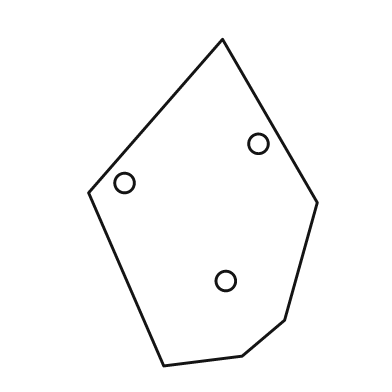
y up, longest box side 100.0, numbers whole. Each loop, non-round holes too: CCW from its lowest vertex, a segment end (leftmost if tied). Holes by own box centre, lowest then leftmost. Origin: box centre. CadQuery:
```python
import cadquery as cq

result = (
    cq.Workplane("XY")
    .moveTo(-12.0, -50.0)
    .lineTo(12.0, -47.0)
    .lineTo(25.0, -36.0)
    .lineTo(35.0, 0.0)
    .lineTo(6.0, 50.0)
    .lineTo(-35.0, 3.0)
    .close()
    .moveTo(7.0, -24.0)
    .circle(3.0)
    .moveTo(-24.0, 6.0)
    .circle(3.0)
    .moveTo(17.0, 18.0)
    .circle(3.0)
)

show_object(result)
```